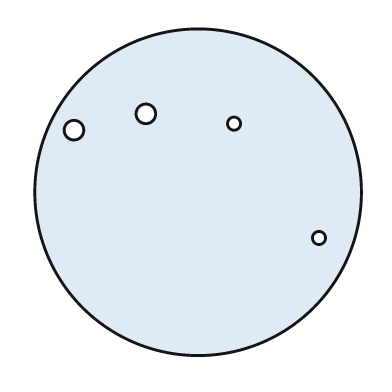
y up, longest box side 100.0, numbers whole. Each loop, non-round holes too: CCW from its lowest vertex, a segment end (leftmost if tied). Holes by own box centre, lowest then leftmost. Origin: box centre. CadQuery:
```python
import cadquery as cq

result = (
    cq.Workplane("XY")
    .moveTo(0.0, 0.0)
    .circle(50.0)
    .moveTo(37.0, -14.0)
    .circle(2.0)
    .moveTo(-38.0, 19.0)
    .circle(3.0)
    .moveTo(11.0, 21.0)
    .circle(2.0)
    .moveTo(-16.0, 24.0)
    .circle(3.0)
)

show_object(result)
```